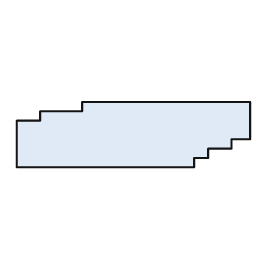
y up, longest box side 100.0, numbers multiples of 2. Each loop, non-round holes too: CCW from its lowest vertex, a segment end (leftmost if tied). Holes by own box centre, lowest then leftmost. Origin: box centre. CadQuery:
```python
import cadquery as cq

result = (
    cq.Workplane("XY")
    .moveTo(-50.0, -14.0)
    .lineTo(26.0, -14.0)
    .lineTo(26.0, -10.0)
    .lineTo(32.0, -10.0)
    .lineTo(32.0, -6.0)
    .lineTo(42.0, -6.0)
    .lineTo(42.0, -2.0)
    .lineTo(50.0, -2.0)
    .lineTo(50.0, 14.0)
    .lineTo(-22.0, 14.0)
    .lineTo(-22.0, 10.0)
    .lineTo(-40.0, 10.0)
    .lineTo(-40.0, 6.0)
    .lineTo(-50.0, 6.0)
    .close()
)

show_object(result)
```